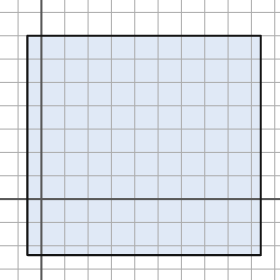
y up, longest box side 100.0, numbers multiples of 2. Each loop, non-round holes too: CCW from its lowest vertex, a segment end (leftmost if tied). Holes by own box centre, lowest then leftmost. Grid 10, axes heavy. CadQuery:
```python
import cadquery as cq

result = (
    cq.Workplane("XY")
    .moveTo(-6.0, -24.0)
    .lineTo(94.0, -24.0)
    .lineTo(94.0, 70.0)
    .lineTo(-6.0, 70.0)
    .close()
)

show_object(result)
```